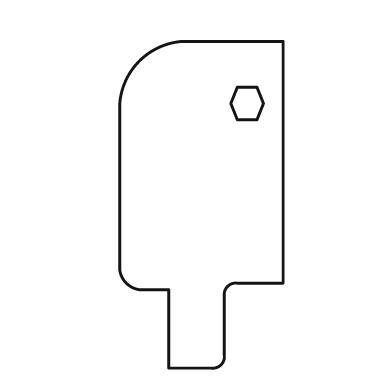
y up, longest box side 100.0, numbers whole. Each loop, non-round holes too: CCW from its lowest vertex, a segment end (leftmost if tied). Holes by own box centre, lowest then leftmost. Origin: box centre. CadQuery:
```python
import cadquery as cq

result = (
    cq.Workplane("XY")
    .moveTo(-10.0, -50.0)
    .lineTo(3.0, -50.0)
    .threePointArc((6.0, -49.0), (7.0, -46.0))
    .lineTo(7.0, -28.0)
    .threePointArc((8.0, -25.0), (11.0, -24.0))
    .lineTo(25.0, -24.0)
    .lineTo(25.0, 50.0)
    .lineTo(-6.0, 50.0)
    .threePointArc((-19.0, 44.0), (-25.0, 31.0))
    .lineTo(-25.0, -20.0)
    .threePointArc((-23.0, -24.0), (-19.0, -26.0))
    .lineTo(-10.0, -26.0)
    .close()
    .moveTo(11.0, 26.0)
    .lineTo(17.0, 26.0)
    .lineTo(19.0, 31.0)
    .lineTo(17.0, 36.0)
    .lineTo(11.0, 36.0)
    .lineTo(9.0, 31.0)
    .close()
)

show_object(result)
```